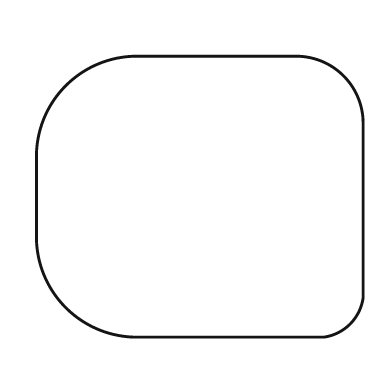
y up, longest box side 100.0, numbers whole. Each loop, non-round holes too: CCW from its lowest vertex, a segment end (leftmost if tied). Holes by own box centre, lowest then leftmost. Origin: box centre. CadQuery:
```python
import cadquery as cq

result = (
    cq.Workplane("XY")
    .moveTo(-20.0, -43.0)
    .lineTo(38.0, -43.0)
    .threePointArc((46.0, -39.0), (50.0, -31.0))
    .lineTo(50.0, 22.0)
    .threePointArc((44.0, 37.0), (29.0, 43.0))
    .lineTo(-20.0, 43.0)
    .threePointArc((-41.0, 34.0), (-50.0, 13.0))
    .lineTo(-50.0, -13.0)
    .threePointArc((-41.0, -34.0), (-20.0, -43.0))
    .close()
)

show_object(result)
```